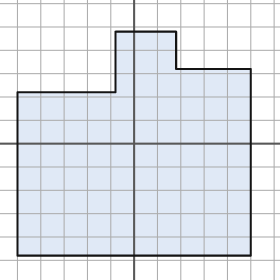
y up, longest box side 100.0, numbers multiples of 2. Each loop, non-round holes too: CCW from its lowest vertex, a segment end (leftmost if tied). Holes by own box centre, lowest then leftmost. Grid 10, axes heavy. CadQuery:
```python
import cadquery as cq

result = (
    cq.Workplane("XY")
    .moveTo(-50.0, -48.0)
    .lineTo(50.0, -48.0)
    .lineTo(50.0, 32.0)
    .lineTo(18.0, 32.0)
    .lineTo(18.0, 48.0)
    .lineTo(-8.0, 48.0)
    .lineTo(-8.0, 22.0)
    .lineTo(-50.0, 22.0)
    .close()
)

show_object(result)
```